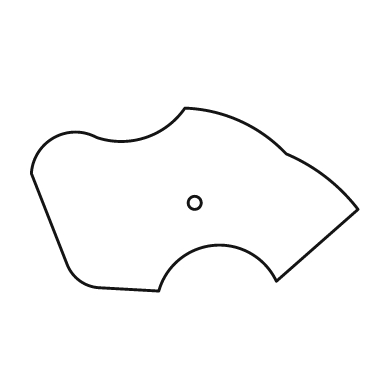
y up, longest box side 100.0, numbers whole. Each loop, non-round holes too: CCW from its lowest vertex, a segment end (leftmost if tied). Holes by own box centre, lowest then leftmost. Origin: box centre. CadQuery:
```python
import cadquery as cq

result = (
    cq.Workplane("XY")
    .moveTo(-11.0, -28.0)
    .threePointArc((6.0, -14.0), (25.0, -25.0))
    .lineTo(50.0, -3.0)
    .threePointArc((40.0, 7.0), (28.0, 14.0))
    .threePointArc((14.0, 24.0), (-3.0, 28.0))
    .threePointArc((-15.0, 19.0), (-30.0, 19.0))
    .threePointArc((-43.0, 19.0), (-50.0, 8.0))
    .lineTo(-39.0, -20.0)
    .threePointArc((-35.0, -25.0), (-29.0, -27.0))
    .close()
    .moveTo(0.0, -1.0)
    .circle(2.0)
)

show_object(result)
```